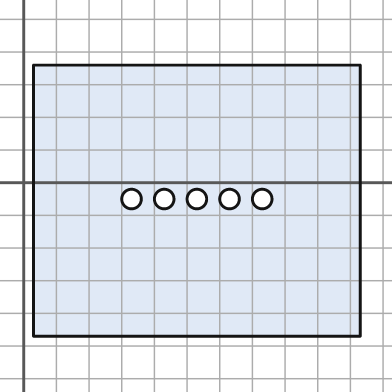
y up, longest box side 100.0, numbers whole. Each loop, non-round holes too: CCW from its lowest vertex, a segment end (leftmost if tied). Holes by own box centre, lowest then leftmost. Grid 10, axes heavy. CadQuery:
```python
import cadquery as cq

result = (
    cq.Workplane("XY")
    .moveTo(3.0, -47.0)
    .lineTo(103.0, -47.0)
    .lineTo(103.0, 36.0)
    .lineTo(3.0, 36.0)
    .close()
    .moveTo(33.0, -5.0)
    .circle(3.0)
    .moveTo(43.0, -5.0)
    .circle(3.0)
    .moveTo(53.0, -5.0)
    .circle(3.0)
    .moveTo(63.0, -5.0)
    .circle(3.0)
    .moveTo(73.0, -5.0)
    .circle(3.0)
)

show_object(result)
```